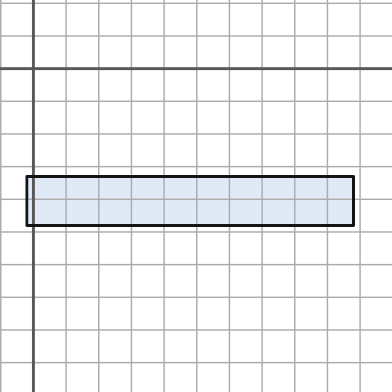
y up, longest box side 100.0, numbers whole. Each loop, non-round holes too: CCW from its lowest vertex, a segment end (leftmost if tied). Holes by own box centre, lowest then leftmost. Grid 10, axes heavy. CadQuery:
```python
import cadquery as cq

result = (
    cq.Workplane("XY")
    .moveTo(-2.0, -48.0)
    .lineTo(98.0, -48.0)
    .lineTo(98.0, -33.0)
    .lineTo(-2.0, -33.0)
    .close()
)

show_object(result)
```